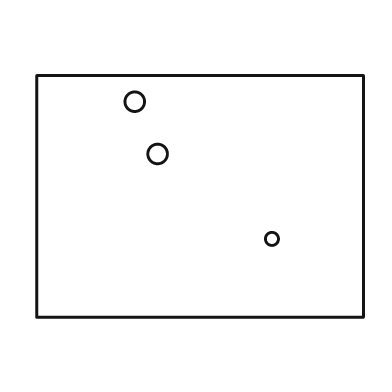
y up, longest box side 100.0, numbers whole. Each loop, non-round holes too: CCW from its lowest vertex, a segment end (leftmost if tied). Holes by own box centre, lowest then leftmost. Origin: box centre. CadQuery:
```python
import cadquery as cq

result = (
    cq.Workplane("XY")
    .moveTo(-50.0, -37.0)
    .lineTo(50.0, -37.0)
    .lineTo(50.0, 37.0)
    .lineTo(-50.0, 37.0)
    .close()
    .moveTo(22.0, -13.0)
    .circle(2.0)
    .moveTo(-13.0, 13.0)
    .circle(3.0)
    .moveTo(-20.0, 29.0)
    .circle(3.0)
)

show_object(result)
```